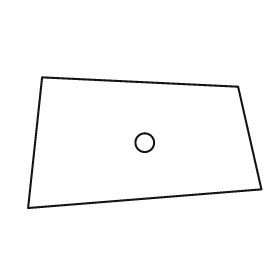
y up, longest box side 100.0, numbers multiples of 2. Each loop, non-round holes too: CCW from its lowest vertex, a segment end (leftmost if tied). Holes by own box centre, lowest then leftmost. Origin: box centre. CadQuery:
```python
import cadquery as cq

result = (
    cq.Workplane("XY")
    .moveTo(-50.0, -28.0)
    .lineTo(50.0, -20.0)
    .lineTo(40.0, 24.0)
    .lineTo(-44.0, 28.0)
    .close()
    .moveTo(0.0, 0.0)
    .circle(4.0)
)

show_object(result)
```